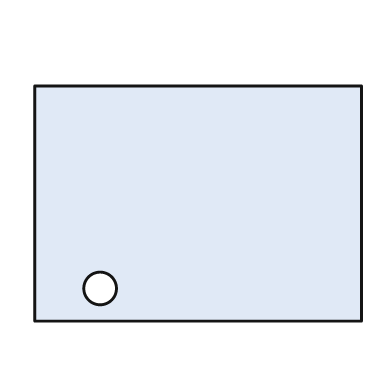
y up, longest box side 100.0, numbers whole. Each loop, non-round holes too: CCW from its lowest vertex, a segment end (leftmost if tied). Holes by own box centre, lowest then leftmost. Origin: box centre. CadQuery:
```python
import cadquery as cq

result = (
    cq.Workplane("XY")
    .moveTo(-50.0, -36.0)
    .lineTo(50.0, -36.0)
    .lineTo(50.0, 36.0)
    .lineTo(-50.0, 36.0)
    .close()
    .moveTo(-30.0, -26.0)
    .circle(5.0)
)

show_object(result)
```